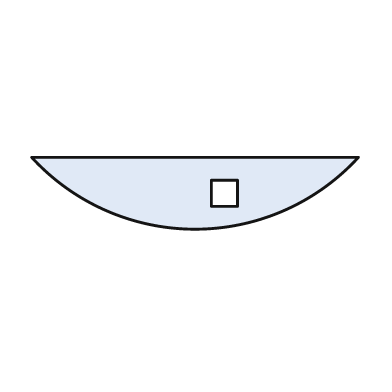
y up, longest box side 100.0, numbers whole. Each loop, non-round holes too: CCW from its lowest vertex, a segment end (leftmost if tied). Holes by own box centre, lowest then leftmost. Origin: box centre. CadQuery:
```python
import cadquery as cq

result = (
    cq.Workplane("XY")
    .moveTo(-50.0, 11.0)
    .threePointArc((0.0, -11.0), (50.0, 11.0))
    .close()
    .moveTo(5.0, -4.0)
    .lineTo(13.0, -4.0)
    .lineTo(13.0, 4.0)
    .lineTo(5.0, 4.0)
    .close()
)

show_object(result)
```